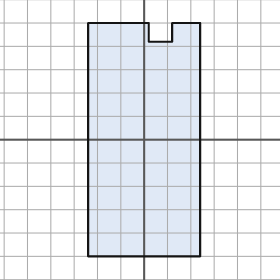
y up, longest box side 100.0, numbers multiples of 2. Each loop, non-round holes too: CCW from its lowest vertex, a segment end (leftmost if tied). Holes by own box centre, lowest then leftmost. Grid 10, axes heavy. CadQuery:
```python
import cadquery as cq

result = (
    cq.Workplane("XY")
    .moveTo(-24.0, -50.0)
    .lineTo(24.0, -50.0)
    .lineTo(24.0, 50.0)
    .lineTo(12.0, 50.0)
    .lineTo(12.0, 42.0)
    .lineTo(2.0, 42.0)
    .lineTo(2.0, 50.0)
    .lineTo(-24.0, 50.0)
    .close()
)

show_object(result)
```